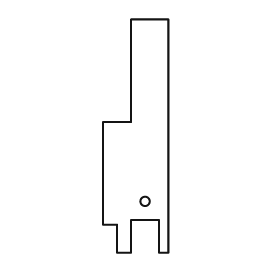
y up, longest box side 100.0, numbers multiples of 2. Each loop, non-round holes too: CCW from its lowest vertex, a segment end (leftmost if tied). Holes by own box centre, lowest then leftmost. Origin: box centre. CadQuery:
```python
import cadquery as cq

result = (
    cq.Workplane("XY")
    .moveTo(-8.0, -50.0)
    .lineTo(-2.0, -50.0)
    .lineTo(-2.0, -36.0)
    .lineTo(10.0, -36.0)
    .lineTo(10.0, -50.0)
    .lineTo(14.0, -50.0)
    .lineTo(14.0, 50.0)
    .lineTo(-2.0, 50.0)
    .lineTo(-2.0, 6.0)
    .lineTo(-14.0, 6.0)
    .lineTo(-14.0, -38.0)
    .lineTo(-8.0, -38.0)
    .close()
    .moveTo(4.0, -28.0)
    .circle(2.0)
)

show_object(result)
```